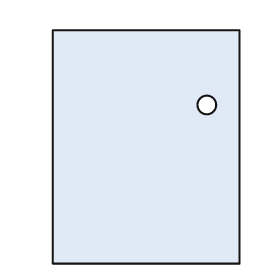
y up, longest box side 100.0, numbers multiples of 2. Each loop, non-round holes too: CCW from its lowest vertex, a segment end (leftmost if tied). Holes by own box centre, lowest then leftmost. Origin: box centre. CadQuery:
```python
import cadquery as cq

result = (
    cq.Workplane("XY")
    .moveTo(-40.0, -50.0)
    .lineTo(40.0, -50.0)
    .lineTo(40.0, 50.0)
    .lineTo(-40.0, 50.0)
    .close()
    .moveTo(26.0, 18.0)
    .circle(4.0)
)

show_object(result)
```